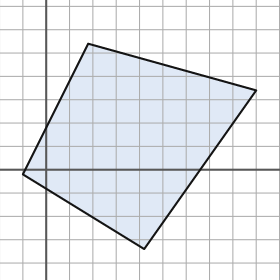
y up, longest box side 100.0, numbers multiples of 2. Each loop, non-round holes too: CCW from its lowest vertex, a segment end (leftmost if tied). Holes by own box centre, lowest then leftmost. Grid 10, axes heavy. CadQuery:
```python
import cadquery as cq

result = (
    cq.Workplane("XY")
    .moveTo(42.0, -34.0)
    .lineTo(90.0, 34.0)
    .lineTo(18.0, 54.0)
    .lineTo(-10.0, -2.0)
    .close()
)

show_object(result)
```